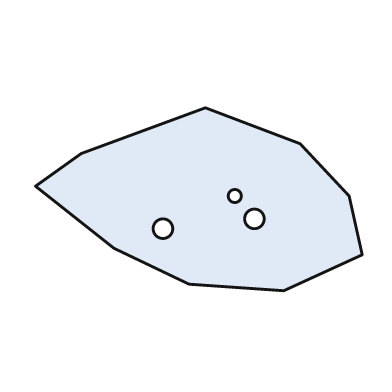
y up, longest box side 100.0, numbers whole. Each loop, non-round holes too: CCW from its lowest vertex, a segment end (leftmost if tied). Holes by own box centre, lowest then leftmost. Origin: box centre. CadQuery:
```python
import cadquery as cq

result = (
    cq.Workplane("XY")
    .moveTo(26.0, -28.0)
    .lineTo(50.0, -17.0)
    .lineTo(46.0, 1.0)
    .lineTo(31.0, 17.0)
    .lineTo(2.0, 28.0)
    .lineTo(-36.0, 14.0)
    .lineTo(-50.0, 4.0)
    .lineTo(-26.0, -15.0)
    .lineTo(-3.0, -26.0)
    .close()
    .moveTo(-11.0, -9.0)
    .circle(3.0)
    .moveTo(17.0, -6.0)
    .circle(3.0)
    .moveTo(11.0, 1.0)
    .circle(2.0)
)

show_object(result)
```